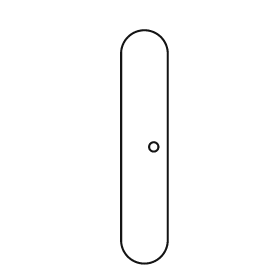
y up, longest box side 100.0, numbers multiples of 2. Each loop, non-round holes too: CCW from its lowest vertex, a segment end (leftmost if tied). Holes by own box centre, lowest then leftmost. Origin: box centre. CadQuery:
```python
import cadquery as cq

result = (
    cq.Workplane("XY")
    .moveTo(-10.0, -40.0)
    .threePointArc((0.0, -50.0), (10.0, -40.0))
    .lineTo(10.0, 40.0)
    .threePointArc((0.0, 50.0), (-10.0, 40.0))
    .close()
    .moveTo(4.0, 0.0)
    .circle(2.0)
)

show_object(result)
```